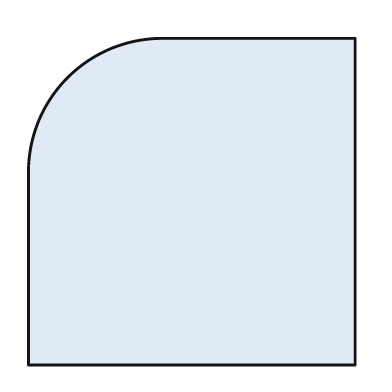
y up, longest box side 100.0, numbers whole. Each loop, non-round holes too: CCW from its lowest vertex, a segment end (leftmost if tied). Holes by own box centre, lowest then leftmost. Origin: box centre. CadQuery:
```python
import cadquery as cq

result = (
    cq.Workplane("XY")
    .moveTo(-50.0, -50.0)
    .lineTo(50.0, -50.0)
    .lineTo(50.0, 50.0)
    .lineTo(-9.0, 50.0)
    .threePointArc((-38.0, 38.0), (-50.0, 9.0))
    .close()
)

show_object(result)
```